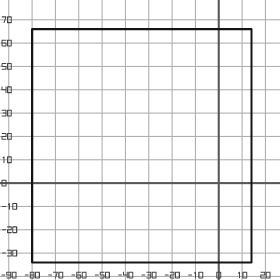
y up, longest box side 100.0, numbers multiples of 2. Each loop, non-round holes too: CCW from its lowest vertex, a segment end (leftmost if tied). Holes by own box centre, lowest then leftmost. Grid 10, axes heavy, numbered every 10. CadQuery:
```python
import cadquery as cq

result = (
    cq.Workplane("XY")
    .moveTo(-80.0, -34.0)
    .lineTo(14.0, -34.0)
    .lineTo(14.0, 66.0)
    .lineTo(-80.0, 66.0)
    .close()
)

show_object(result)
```